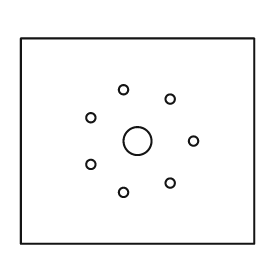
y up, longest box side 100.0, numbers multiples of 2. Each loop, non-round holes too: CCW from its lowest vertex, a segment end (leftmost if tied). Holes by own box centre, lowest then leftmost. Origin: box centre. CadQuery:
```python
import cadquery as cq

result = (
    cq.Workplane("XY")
    .moveTo(-50.0, -44.0)
    .lineTo(50.0, -44.0)
    .lineTo(50.0, 44.0)
    .lineTo(-50.0, 44.0)
    .close()
    .moveTo(-6.0, -22.0)
    .circle(2.0)
    .moveTo(14.0, -18.0)
    .circle(2.0)
    .moveTo(-20.0, -10.0)
    .circle(2.0)
    .moveTo(0.0, 0.0)
    .circle(6.0)
    .moveTo(24.0, 0.0)
    .circle(2.0)
    .moveTo(-20.0, 10.0)
    .circle(2.0)
    .moveTo(14.0, 18.0)
    .circle(2.0)
    .moveTo(-6.0, 22.0)
    .circle(2.0)
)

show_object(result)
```